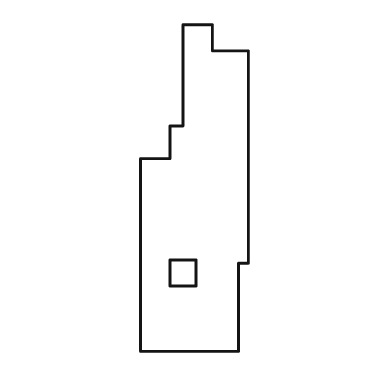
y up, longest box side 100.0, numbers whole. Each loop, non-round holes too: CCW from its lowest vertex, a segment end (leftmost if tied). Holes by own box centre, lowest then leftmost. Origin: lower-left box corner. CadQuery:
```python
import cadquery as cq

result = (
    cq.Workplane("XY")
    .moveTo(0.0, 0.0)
    .lineTo(30.0, 0.0)
    .lineTo(30.0, 27.0)
    .lineTo(33.0, 27.0)
    .lineTo(33.0, 92.0)
    .lineTo(22.0, 92.0)
    .lineTo(22.0, 100.0)
    .lineTo(13.0, 100.0)
    .lineTo(13.0, 69.0)
    .lineTo(9.0, 69.0)
    .lineTo(9.0, 59.0)
    .lineTo(0.0, 59.0)
    .close()
    .moveTo(9.0, 20.0)
    .lineTo(17.0, 20.0)
    .lineTo(17.0, 28.0)
    .lineTo(9.0, 28.0)
    .close()
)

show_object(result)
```